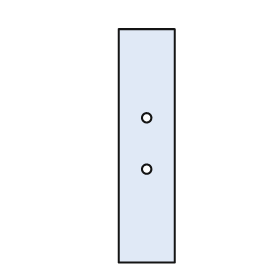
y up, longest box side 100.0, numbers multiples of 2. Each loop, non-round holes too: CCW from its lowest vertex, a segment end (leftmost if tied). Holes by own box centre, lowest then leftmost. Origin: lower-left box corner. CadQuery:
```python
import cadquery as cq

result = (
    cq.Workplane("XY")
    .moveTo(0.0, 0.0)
    .lineTo(24.0, 0.0)
    .lineTo(24.0, 100.0)
    .lineTo(0.0, 100.0)
    .close()
    .moveTo(12.0, 40.0)
    .circle(2.0)
    .moveTo(12.0, 62.0)
    .circle(2.0)
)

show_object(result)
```